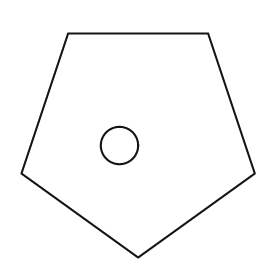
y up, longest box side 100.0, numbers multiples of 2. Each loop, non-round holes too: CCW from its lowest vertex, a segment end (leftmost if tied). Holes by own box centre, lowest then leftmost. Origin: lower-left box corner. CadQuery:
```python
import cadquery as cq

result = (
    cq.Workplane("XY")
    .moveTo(50.0, 0.0)
    .lineTo(100.0, 36.0)
    .lineTo(80.0, 96.0)
    .lineTo(20.0, 96.0)
    .lineTo(0.0, 36.0)
    .close()
    .moveTo(42.0, 48.0)
    .circle(8.0)
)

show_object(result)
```